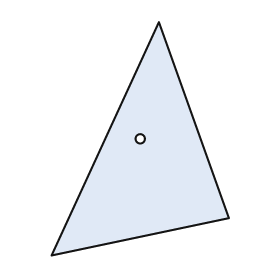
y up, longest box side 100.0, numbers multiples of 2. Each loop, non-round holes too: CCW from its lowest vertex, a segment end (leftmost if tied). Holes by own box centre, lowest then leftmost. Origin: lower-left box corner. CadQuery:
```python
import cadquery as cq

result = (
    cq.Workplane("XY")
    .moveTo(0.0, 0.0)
    .lineTo(76.0, 16.0)
    .lineTo(46.0, 100.0)
    .close()
    .moveTo(38.0, 50.0)
    .circle(2.0)
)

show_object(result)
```